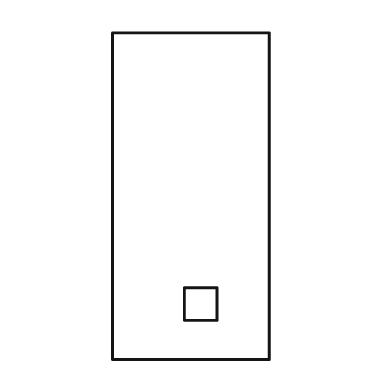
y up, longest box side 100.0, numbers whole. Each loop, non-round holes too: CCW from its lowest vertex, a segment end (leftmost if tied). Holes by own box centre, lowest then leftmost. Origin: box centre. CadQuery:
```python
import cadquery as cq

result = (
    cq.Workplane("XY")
    .moveTo(-24.0, -50.0)
    .lineTo(24.0, -50.0)
    .lineTo(24.0, 50.0)
    .lineTo(-24.0, 50.0)
    .close()
    .moveTo(-2.0, -38.0)
    .lineTo(8.0, -38.0)
    .lineTo(8.0, -28.0)
    .lineTo(-2.0, -28.0)
    .close()
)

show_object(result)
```